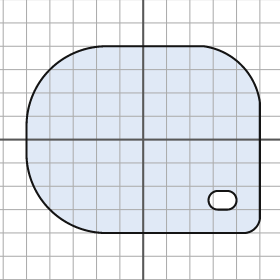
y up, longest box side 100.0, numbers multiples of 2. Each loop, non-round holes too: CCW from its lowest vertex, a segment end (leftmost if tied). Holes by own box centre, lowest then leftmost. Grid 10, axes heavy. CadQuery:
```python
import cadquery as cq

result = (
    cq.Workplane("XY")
    .moveTo(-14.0, -40.0)
    .lineTo(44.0, -40.0)
    .threePointArc((48.0, -38.0), (50.0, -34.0))
    .lineTo(50.0, 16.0)
    .threePointArc((42.0, 32.0), (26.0, 40.0))
    .lineTo(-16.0, 40.0)
    .threePointArc((-40.0, 30.0), (-50.0, 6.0))
    .lineTo(-50.0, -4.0)
    .threePointArc((-40.0, -30.0), (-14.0, -40.0))
    .close()
    .moveTo(32.0, -30.0)
    .lineTo(36.0, -30.0)
    .threePointArc((40.0, -26.0), (36.0, -22.0))
    .lineTo(32.0, -22.0)
    .threePointArc((28.0, -26.0), (32.0, -30.0))
    .close()
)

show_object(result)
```